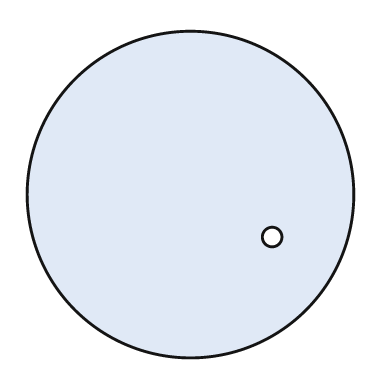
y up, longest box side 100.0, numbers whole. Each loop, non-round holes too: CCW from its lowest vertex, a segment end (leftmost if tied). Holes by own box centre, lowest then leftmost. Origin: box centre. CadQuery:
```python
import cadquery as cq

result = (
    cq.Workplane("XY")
    .moveTo(0.0, 0.0)
    .circle(50.0)
    .moveTo(25.0, -13.0)
    .circle(3.0)
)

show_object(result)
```